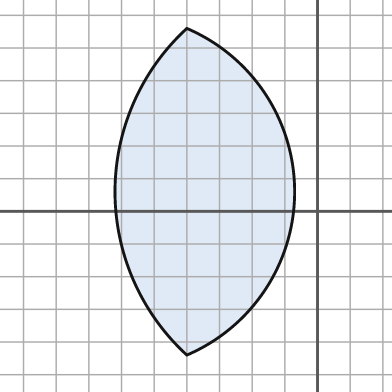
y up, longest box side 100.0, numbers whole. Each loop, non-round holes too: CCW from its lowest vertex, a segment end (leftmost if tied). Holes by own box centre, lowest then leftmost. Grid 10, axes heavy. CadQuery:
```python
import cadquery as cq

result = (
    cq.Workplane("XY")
    .moveTo(-40.0, -44.0)
    .threePointArc((-7.0, 6.0), (-40.0, 56.0))
    .threePointArc((-62.0, 6.0), (-40.0, -44.0))
    .close()
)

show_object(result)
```